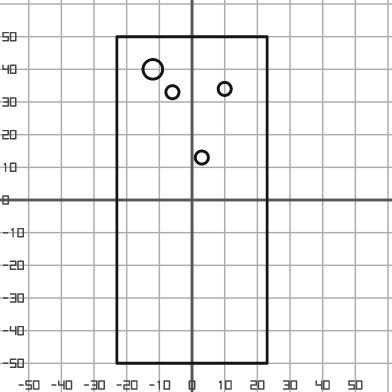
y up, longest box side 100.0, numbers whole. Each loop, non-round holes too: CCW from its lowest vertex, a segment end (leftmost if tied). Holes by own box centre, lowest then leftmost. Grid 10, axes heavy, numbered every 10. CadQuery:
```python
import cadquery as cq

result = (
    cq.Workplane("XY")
    .moveTo(-23.0, -50.0)
    .lineTo(23.0, -50.0)
    .lineTo(23.0, 50.0)
    .lineTo(-23.0, 50.0)
    .close()
    .moveTo(3.0, 13.0)
    .circle(2.0)
    .moveTo(-6.0, 33.0)
    .circle(2.0)
    .moveTo(10.0, 34.0)
    .circle(2.0)
    .moveTo(-12.0, 40.0)
    .circle(3.0)
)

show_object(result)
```